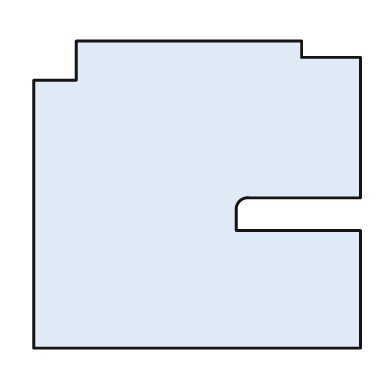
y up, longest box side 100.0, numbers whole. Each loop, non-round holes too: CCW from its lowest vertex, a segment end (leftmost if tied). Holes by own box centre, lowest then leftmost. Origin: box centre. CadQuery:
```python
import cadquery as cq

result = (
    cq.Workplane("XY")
    .moveTo(-50.0, -47.0)
    .lineTo(50.0, -47.0)
    .lineTo(50.0, -11.0)
    .lineTo(12.0, -11.0)
    .lineTo(12.0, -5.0)
    .threePointArc((13.0, -2.0), (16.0, -1.0))
    .lineTo(50.0, -1.0)
    .lineTo(50.0, 42.0)
    .lineTo(32.0, 42.0)
    .lineTo(32.0, 47.0)
    .lineTo(-37.0, 47.0)
    .lineTo(-37.0, 35.0)
    .lineTo(-50.0, 35.0)
    .close()
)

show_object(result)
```